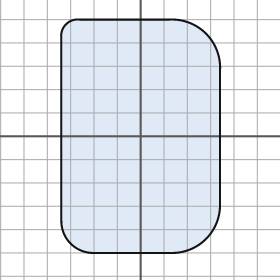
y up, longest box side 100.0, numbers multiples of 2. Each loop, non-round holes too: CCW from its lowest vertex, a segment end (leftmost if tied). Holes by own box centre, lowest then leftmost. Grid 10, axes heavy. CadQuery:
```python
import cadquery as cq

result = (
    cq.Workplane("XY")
    .moveTo(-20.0, -50.0)
    .lineTo(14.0, -50.0)
    .threePointArc((28.0, -44.0), (34.0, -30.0))
    .lineTo(34.0, 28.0)
    .threePointArc((28.0, 44.0), (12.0, 50.0))
    .lineTo(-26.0, 50.0)
    .threePointArc((-32.0, 48.0), (-34.0, 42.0))
    .lineTo(-34.0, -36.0)
    .threePointArc((-30.0, -46.0), (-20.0, -50.0))
    .close()
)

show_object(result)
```